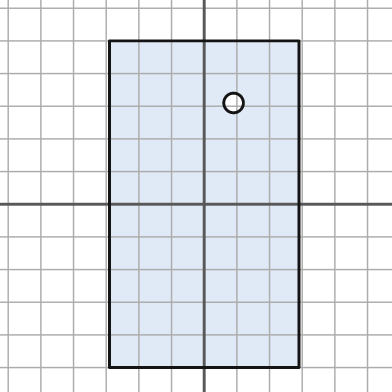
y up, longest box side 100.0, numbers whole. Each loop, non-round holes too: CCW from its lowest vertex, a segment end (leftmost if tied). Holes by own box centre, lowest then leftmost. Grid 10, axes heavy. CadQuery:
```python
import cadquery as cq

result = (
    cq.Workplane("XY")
    .moveTo(-29.0, -50.0)
    .lineTo(29.0, -50.0)
    .lineTo(29.0, 50.0)
    .lineTo(-29.0, 50.0)
    .close()
    .moveTo(9.0, 31.0)
    .circle(3.0)
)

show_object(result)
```